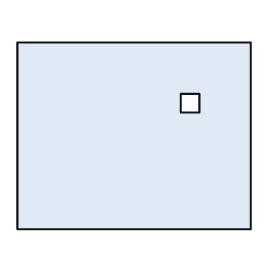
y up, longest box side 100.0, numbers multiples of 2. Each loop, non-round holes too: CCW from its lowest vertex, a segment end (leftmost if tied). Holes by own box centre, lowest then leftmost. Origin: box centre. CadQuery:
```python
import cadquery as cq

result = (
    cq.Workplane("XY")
    .moveTo(-50.0, -40.0)
    .lineTo(50.0, -40.0)
    .lineTo(50.0, 40.0)
    .lineTo(-50.0, 40.0)
    .close()
    .moveTo(20.0, 10.0)
    .lineTo(28.0, 10.0)
    .lineTo(28.0, 18.0)
    .lineTo(20.0, 18.0)
    .close()
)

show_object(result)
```